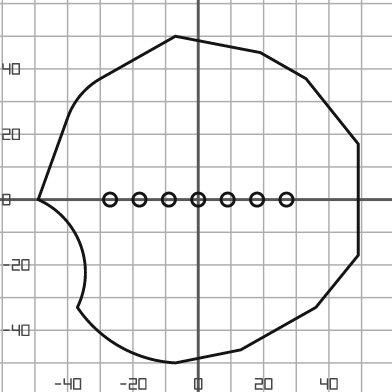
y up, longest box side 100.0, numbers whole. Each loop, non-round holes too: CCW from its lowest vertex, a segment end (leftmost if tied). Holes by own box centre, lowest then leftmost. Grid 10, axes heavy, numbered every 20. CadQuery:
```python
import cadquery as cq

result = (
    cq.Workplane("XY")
    .moveTo(-7.0, -50.0)
    .lineTo(13.0, -46.0)
    .lineTo(36.0, -33.0)
    .lineTo(49.0, -17.0)
    .lineTo(49.0, 17.0)
    .lineTo(33.0, 37.0)
    .lineTo(19.0, 45.0)
    .lineTo(-7.0, 50.0)
    .lineTo(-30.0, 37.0)
    .threePointArc((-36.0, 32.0), (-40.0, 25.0))
    .lineTo(-49.0, 0.0)
    .threePointArc((-36.0, -14.0), (-37.0, -33.0))
    .threePointArc((-24.0, -45.0), (-7.0, -50.0))
    .close()
    .moveTo(-27.0, 0.0)
    .circle(2.0)
    .moveTo(-18.0, 0.0)
    .circle(2.0)
    .moveTo(-9.0, 0.0)
    .circle(2.0)
    .moveTo(0.0, 0.0)
    .circle(2.0)
    .moveTo(9.0, 0.0)
    .circle(2.0)
    .moveTo(18.0, 0.0)
    .circle(2.0)
    .moveTo(27.0, 0.0)
    .circle(2.0)
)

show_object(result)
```